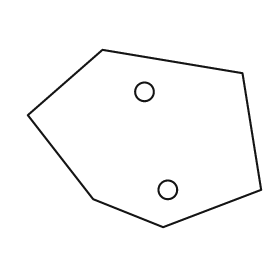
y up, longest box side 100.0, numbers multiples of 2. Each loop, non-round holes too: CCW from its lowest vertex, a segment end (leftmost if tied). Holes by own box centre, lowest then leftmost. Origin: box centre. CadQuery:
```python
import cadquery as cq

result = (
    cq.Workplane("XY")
    .moveTo(8.0, -38.0)
    .lineTo(50.0, -22.0)
    .lineTo(42.0, 28.0)
    .lineTo(-18.0, 38.0)
    .lineTo(-50.0, 10.0)
    .lineTo(-22.0, -26.0)
    .close()
    .moveTo(10.0, -22.0)
    .circle(4.0)
    .moveTo(0.0, 20.0)
    .circle(4.0)
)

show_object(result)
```